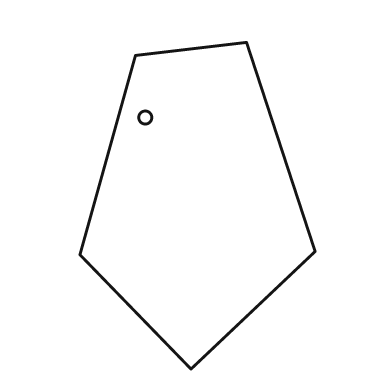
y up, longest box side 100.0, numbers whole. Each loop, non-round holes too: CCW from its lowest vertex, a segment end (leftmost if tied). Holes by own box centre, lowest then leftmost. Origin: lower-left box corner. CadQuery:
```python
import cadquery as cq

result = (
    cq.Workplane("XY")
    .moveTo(34.0, 0.0)
    .lineTo(72.0, 36.0)
    .lineTo(51.0, 100.0)
    .lineTo(17.0, 96.0)
    .lineTo(0.0, 35.0)
    .close()
    .moveTo(20.0, 77.0)
    .circle(2.0)
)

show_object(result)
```